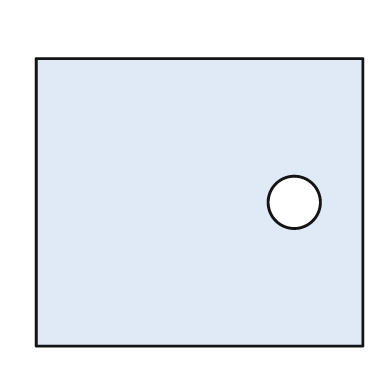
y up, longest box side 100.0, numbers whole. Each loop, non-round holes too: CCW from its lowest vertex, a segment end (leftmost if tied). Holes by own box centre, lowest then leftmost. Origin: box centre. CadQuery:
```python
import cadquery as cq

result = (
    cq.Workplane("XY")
    .moveTo(-50.0, -44.0)
    .lineTo(50.0, -44.0)
    .lineTo(50.0, 44.0)
    .lineTo(-50.0, 44.0)
    .close()
    .moveTo(29.0, 0.0)
    .circle(8.0)
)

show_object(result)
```